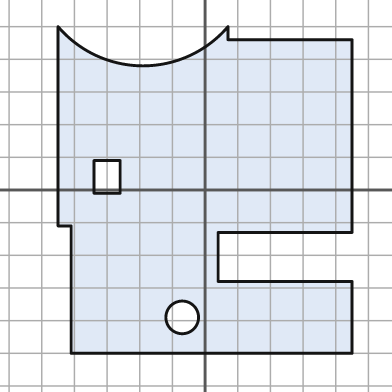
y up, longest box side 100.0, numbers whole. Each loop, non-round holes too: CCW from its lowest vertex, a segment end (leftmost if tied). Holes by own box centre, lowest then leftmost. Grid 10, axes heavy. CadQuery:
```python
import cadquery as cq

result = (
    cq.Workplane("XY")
    .moveTo(-41.0, -50.0)
    .lineTo(45.0, -50.0)
    .lineTo(45.0, -28.0)
    .lineTo(4.0, -28.0)
    .lineTo(4.0, -13.0)
    .lineTo(45.0, -13.0)
    .lineTo(45.0, 46.0)
    .lineTo(7.0, 46.0)
    .lineTo(7.0, 50.0)
    .threePointArc((-19.0, 38.0), (-45.0, 50.0))
    .lineTo(-45.0, -11.0)
    .lineTo(-41.0, -11.0)
    .close()
    .moveTo(-7.0, -39.0)
    .circle(5.0)
    .moveTo(-34.0, -1.0)
    .lineTo(-26.0, -1.0)
    .lineTo(-26.0, 9.0)
    .lineTo(-34.0, 9.0)
    .close()
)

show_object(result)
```